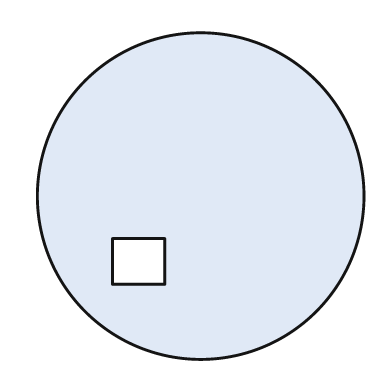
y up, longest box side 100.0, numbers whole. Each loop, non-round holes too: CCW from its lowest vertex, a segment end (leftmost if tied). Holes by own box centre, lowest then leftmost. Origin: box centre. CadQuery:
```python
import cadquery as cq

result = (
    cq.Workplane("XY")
    .moveTo(0.0, 0.0)
    .circle(50.0)
    .moveTo(-27.0, -27.0)
    .lineTo(-11.0, -27.0)
    .lineTo(-11.0, -13.0)
    .lineTo(-27.0, -13.0)
    .close()
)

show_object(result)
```